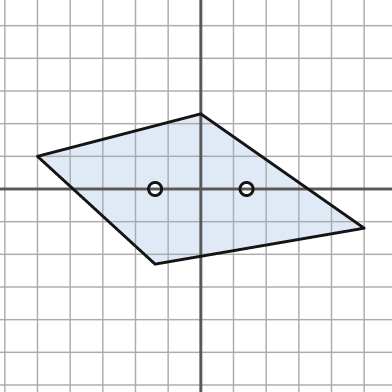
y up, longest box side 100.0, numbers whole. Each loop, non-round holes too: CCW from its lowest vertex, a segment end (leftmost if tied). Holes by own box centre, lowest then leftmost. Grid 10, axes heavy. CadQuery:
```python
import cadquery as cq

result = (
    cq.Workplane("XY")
    .moveTo(-14.0, -23.0)
    .lineTo(50.0, -12.0)
    .lineTo(0.0, 23.0)
    .lineTo(-50.0, 10.0)
    .close()
    .moveTo(-14.0, 0.0)
    .circle(2.0)
    .moveTo(14.0, 0.0)
    .circle(2.0)
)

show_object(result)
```